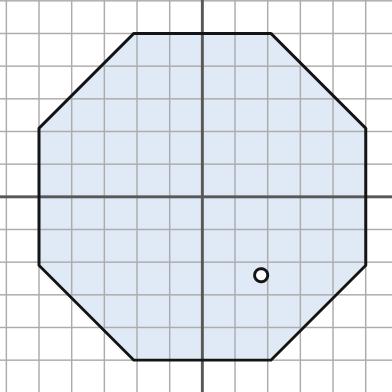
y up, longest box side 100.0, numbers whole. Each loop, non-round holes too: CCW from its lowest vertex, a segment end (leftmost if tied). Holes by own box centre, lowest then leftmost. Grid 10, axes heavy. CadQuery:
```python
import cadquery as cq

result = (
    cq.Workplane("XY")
    .moveTo(-21.0, -50.0)
    .lineTo(21.0, -50.0)
    .lineTo(50.0, -21.0)
    .lineTo(50.0, 21.0)
    .lineTo(21.0, 50.0)
    .lineTo(-21.0, 50.0)
    .lineTo(-50.0, 21.0)
    .lineTo(-50.0, -21.0)
    .close()
    .moveTo(18.0, -24.0)
    .circle(2.0)
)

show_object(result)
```